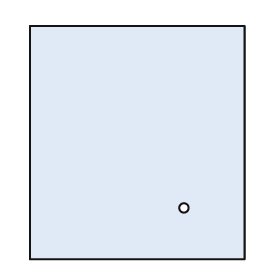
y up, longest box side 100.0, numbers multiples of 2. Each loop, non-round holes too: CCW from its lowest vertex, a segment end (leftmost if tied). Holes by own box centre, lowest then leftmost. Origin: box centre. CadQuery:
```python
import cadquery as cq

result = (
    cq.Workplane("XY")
    .moveTo(-46.0, -50.0)
    .lineTo(46.0, -50.0)
    .lineTo(46.0, 50.0)
    .lineTo(-46.0, 50.0)
    .close()
    .moveTo(20.0, -28.0)
    .circle(2.0)
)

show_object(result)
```